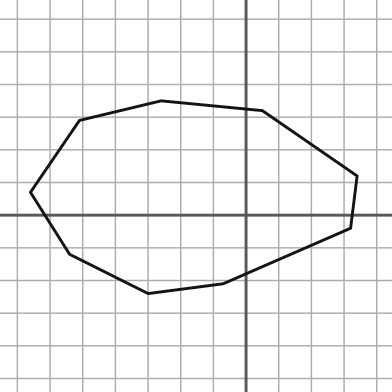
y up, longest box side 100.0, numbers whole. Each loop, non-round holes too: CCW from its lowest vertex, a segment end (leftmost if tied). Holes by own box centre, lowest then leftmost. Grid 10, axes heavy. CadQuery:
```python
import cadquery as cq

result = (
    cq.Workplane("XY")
    .moveTo(-30.0, -24.0)
    .lineTo(-7.0, -21.0)
    .lineTo(32.0, -4.0)
    .lineTo(34.0, 12.0)
    .lineTo(5.0, 32.0)
    .lineTo(-26.0, 35.0)
    .lineTo(-51.0, 29.0)
    .lineTo(-66.0, 7.0)
    .lineTo(-54.0, -12.0)
    .close()
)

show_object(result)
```